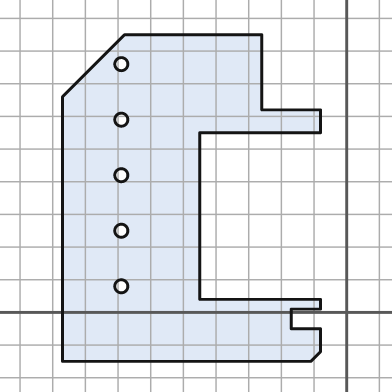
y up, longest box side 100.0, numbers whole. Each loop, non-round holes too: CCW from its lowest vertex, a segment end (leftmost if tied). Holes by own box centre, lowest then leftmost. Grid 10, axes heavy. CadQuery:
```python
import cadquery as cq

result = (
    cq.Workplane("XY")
    .moveTo(-87.0, -15.0)
    .lineTo(-11.0, -15.0)
    .lineTo(-8.0, -12.0)
    .lineTo(-8.0, -5.0)
    .lineTo(-17.0, -5.0)
    .lineTo(-17.0, 1.0)
    .lineTo(-8.0, 1.0)
    .lineTo(-8.0, 4.0)
    .lineTo(-45.0, 4.0)
    .lineTo(-45.0, 55.0)
    .lineTo(-8.0, 55.0)
    .lineTo(-8.0, 62.0)
    .lineTo(-26.0, 62.0)
    .lineTo(-26.0, 85.0)
    .lineTo(-68.0, 85.0)
    .lineTo(-87.0, 66.0)
    .close()
    .moveTo(-69.0, 8.0)
    .circle(2.0)
    .moveTo(-69.0, 25.0)
    .circle(2.0)
    .moveTo(-69.0, 42.0)
    .circle(2.0)
    .moveTo(-69.0, 59.0)
    .circle(2.0)
    .moveTo(-69.0, 76.0)
    .circle(2.0)
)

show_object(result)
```